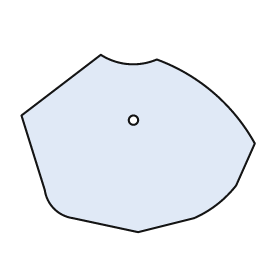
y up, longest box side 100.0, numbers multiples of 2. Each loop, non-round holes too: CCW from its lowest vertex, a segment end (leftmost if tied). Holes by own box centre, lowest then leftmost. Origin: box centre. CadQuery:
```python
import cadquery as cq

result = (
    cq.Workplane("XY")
    .moveTo(0.0, -38.0)
    .lineTo(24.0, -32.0)
    .threePointArc((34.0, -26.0), (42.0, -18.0))
    .lineTo(50.0, 0.0)
    .threePointArc((32.0, 22.0), (8.0, 36.0))
    .threePointArc((-4.0, 34.0), (-16.0, 38.0))
    .lineTo(-50.0, 12.0)
    .lineTo(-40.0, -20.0)
    .threePointArc((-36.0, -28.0), (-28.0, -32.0))
    .close()
    .moveTo(-2.0, 10.0)
    .circle(2.0)
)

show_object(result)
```